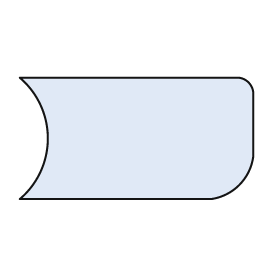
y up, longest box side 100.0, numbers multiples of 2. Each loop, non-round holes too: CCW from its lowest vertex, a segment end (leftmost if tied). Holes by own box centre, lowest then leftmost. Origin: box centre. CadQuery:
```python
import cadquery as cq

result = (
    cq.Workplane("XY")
    .moveTo(-50.0, -26.0)
    .lineTo(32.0, -26.0)
    .threePointArc((44.0, -20.0), (50.0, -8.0))
    .lineTo(50.0, 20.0)
    .threePointArc((48.0, 24.0), (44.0, 26.0))
    .lineTo(-50.0, 26.0)
    .threePointArc((-38.0, 0.0), (-50.0, -26.0))
    .close()
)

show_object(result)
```